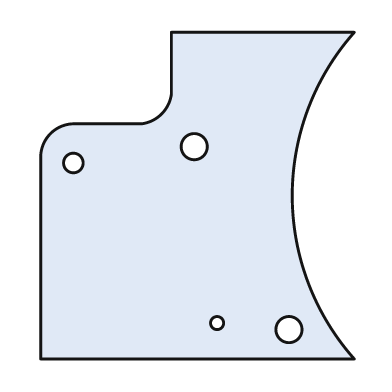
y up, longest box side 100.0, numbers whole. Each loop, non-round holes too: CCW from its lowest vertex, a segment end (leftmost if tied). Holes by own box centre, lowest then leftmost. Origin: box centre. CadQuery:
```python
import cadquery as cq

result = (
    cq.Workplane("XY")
    .moveTo(-48.0, -50.0)
    .lineTo(48.0, -50.0)
    .threePointArc((29.0, 0.0), (48.0, 50.0))
    .lineTo(-8.0, 50.0)
    .lineTo(-8.0, 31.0)
    .threePointArc((-11.0, 25.0), (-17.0, 22.0))
    .lineTo(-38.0, 22.0)
    .threePointArc((-45.0, 19.0), (-48.0, 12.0))
    .close()
    .moveTo(28.0, -41.0)
    .circle(4.0)
    .moveTo(6.0, -39.0)
    .circle(2.0)
    .moveTo(-38.0, 10.0)
    .circle(3.0)
    .moveTo(-1.0, 15.0)
    .circle(4.0)
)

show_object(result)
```